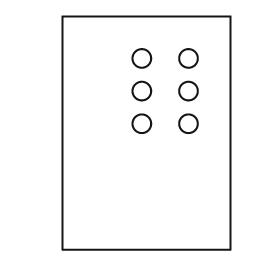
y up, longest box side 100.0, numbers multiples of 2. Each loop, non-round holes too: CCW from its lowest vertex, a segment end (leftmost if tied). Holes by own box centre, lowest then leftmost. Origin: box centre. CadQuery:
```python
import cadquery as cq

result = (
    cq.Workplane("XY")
    .moveTo(-36.0, -50.0)
    .lineTo(36.0, -50.0)
    .lineTo(36.0, 50.0)
    .lineTo(-36.0, 50.0)
    .close()
    .moveTo(-2.0, 4.0)
    .circle(4.0)
    .moveTo(18.0, 4.0)
    .circle(4.0)
    .moveTo(-2.0, 18.0)
    .circle(4.0)
    .moveTo(18.0, 18.0)
    .circle(4.0)
    .moveTo(-2.0, 32.0)
    .circle(4.0)
    .moveTo(18.0, 32.0)
    .circle(4.0)
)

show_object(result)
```